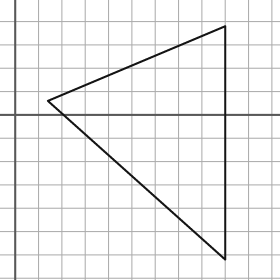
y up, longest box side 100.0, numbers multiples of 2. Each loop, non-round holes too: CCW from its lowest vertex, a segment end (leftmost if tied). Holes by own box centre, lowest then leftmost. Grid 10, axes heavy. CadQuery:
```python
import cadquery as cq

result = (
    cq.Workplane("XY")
    .moveTo(90.0, -62.0)
    .lineTo(90.0, 38.0)
    .lineTo(14.0, 6.0)
    .close()
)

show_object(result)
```